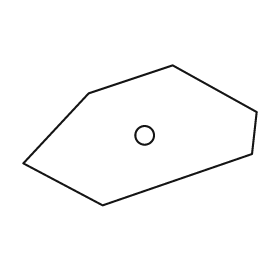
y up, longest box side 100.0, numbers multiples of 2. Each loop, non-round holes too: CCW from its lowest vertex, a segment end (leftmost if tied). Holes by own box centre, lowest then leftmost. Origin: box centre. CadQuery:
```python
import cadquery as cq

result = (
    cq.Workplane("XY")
    .moveTo(-16.0, -30.0)
    .lineTo(48.0, -8.0)
    .lineTo(50.0, 10.0)
    .lineTo(14.0, 30.0)
    .lineTo(-22.0, 18.0)
    .lineTo(-50.0, -12.0)
    .close()
    .moveTo(2.0, 0.0)
    .circle(4.0)
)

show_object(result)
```